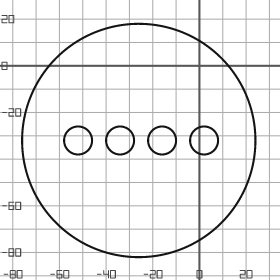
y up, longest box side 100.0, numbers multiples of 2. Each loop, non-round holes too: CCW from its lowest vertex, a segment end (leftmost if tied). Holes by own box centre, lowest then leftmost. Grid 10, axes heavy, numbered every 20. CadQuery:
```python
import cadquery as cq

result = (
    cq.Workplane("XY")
    .moveTo(-26.0, -32.0)
    .circle(50.0)
    .moveTo(-52.0, -32.0)
    .circle(6.0)
    .moveTo(-34.0, -32.0)
    .circle(6.0)
    .moveTo(-16.0, -32.0)
    .circle(6.0)
    .moveTo(2.0, -32.0)
    .circle(6.0)
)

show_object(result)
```